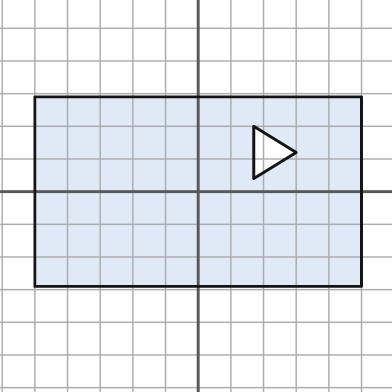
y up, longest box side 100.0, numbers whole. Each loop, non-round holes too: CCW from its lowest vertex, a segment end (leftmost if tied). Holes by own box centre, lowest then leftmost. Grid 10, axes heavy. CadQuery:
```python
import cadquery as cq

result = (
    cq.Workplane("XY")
    .moveTo(-50.0, -29.0)
    .lineTo(50.0, -29.0)
    .lineTo(50.0, 29.0)
    .lineTo(-50.0, 29.0)
    .close()
    .moveTo(17.0, 4.0)
    .lineTo(30.0, 12.0)
    .lineTo(17.0, 20.0)
    .close()
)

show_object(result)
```